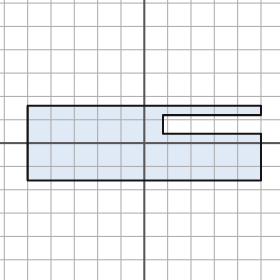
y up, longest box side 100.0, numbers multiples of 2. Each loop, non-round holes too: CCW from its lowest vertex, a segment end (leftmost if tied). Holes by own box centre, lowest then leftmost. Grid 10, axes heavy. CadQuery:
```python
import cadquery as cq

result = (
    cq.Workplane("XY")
    .moveTo(-50.0, -16.0)
    .lineTo(50.0, -16.0)
    .lineTo(50.0, 4.0)
    .lineTo(8.0, 4.0)
    .lineTo(8.0, 12.0)
    .lineTo(50.0, 12.0)
    .lineTo(50.0, 16.0)
    .lineTo(-50.0, 16.0)
    .close()
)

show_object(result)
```